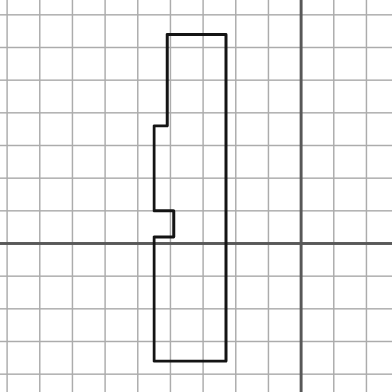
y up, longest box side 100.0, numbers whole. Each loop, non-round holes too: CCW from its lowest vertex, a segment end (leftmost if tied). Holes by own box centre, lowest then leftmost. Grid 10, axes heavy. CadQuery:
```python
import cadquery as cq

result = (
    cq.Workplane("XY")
    .moveTo(-45.0, -36.0)
    .lineTo(-23.0, -36.0)
    .lineTo(-23.0, 64.0)
    .lineTo(-41.0, 64.0)
    .lineTo(-41.0, 36.0)
    .lineTo(-45.0, 36.0)
    .lineTo(-45.0, 10.0)
    .lineTo(-39.0, 10.0)
    .lineTo(-39.0, 2.0)
    .lineTo(-45.0, 2.0)
    .close()
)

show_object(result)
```